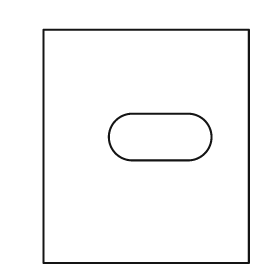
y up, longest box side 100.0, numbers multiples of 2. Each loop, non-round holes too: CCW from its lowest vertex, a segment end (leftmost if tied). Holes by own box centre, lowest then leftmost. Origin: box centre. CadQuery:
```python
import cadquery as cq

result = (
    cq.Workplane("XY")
    .moveTo(-44.0, -50.0)
    .lineTo(44.0, -50.0)
    .lineTo(44.0, 50.0)
    .lineTo(-44.0, 50.0)
    .close()
    .moveTo(-6.0, -6.0)
    .lineTo(18.0, -6.0)
    .threePointArc((28.0, 4.0), (18.0, 14.0))
    .lineTo(-6.0, 14.0)
    .threePointArc((-16.0, 4.0), (-6.0, -6.0))
    .close()
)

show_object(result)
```